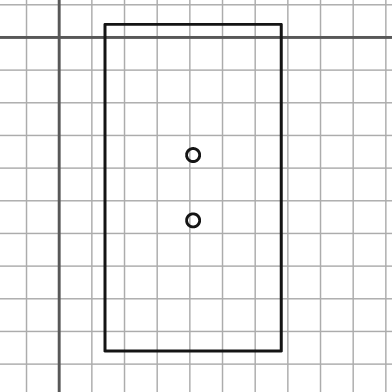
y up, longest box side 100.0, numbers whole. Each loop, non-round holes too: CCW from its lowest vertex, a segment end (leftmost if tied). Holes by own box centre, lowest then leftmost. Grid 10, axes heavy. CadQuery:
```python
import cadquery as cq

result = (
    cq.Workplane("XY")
    .moveTo(14.0, -96.0)
    .lineTo(68.0, -96.0)
    .lineTo(68.0, 4.0)
    .lineTo(14.0, 4.0)
    .close()
    .moveTo(41.0, -56.0)
    .circle(2.0)
    .moveTo(41.0, -36.0)
    .circle(2.0)
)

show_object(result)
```